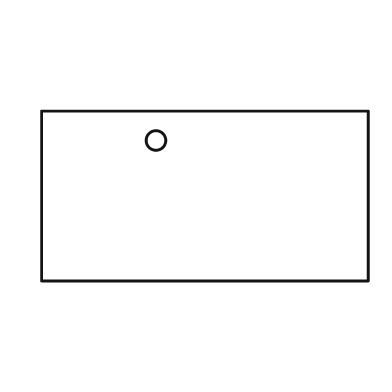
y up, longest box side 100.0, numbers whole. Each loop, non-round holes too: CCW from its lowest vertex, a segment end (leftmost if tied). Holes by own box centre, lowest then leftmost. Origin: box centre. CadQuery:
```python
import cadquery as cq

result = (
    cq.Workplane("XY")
    .moveTo(-50.0, -26.0)
    .lineTo(50.0, -26.0)
    .lineTo(50.0, 26.0)
    .lineTo(-50.0, 26.0)
    .close()
    .moveTo(-15.0, 17.0)
    .circle(3.0)
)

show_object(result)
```